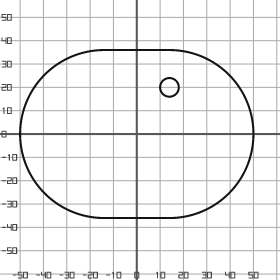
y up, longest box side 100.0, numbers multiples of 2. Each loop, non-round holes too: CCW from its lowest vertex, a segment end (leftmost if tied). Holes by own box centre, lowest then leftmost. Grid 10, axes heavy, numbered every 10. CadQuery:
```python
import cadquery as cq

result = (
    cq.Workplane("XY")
    .moveTo(-14.0, -36.0)
    .lineTo(14.0, -36.0)
    .threePointArc((50.0, 0.0), (14.0, 36.0))
    .lineTo(-14.0, 36.0)
    .threePointArc((-50.0, 0.0), (-14.0, -36.0))
    .close()
    .moveTo(14.0, 20.0)
    .circle(4.0)
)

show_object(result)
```